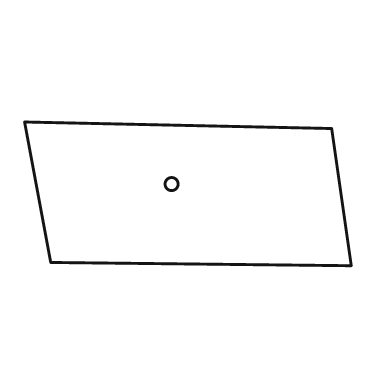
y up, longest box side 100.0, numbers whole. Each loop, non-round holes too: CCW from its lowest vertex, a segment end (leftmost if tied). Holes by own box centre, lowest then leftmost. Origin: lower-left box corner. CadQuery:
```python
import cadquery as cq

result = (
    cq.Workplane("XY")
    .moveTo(100.0, 0.0)
    .lineTo(94.0, 42.0)
    .lineTo(0.0, 44.0)
    .lineTo(8.0, 1.0)
    .close()
    .moveTo(45.0, 25.0)
    .circle(2.0)
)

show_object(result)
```